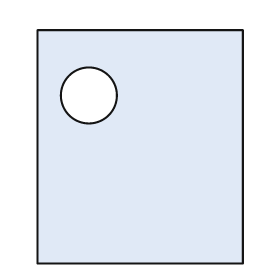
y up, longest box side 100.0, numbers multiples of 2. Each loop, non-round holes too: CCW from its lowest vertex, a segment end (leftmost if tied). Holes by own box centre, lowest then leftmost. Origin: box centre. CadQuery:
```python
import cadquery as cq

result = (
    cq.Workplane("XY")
    .moveTo(-44.0, -50.0)
    .lineTo(44.0, -50.0)
    .lineTo(44.0, 50.0)
    .lineTo(-44.0, 50.0)
    .close()
    .moveTo(-22.0, 22.0)
    .circle(12.0)
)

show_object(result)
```